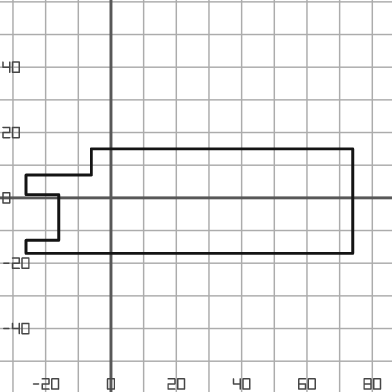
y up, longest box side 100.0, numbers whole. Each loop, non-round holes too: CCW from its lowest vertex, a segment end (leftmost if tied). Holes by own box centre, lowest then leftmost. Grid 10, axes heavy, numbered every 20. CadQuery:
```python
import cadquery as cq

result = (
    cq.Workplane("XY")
    .moveTo(-26.0, -17.0)
    .lineTo(74.0, -17.0)
    .lineTo(74.0, 15.0)
    .lineTo(-6.0, 15.0)
    .lineTo(-6.0, 7.0)
    .lineTo(-26.0, 7.0)
    .lineTo(-26.0, 1.0)
    .lineTo(-16.0, 1.0)
    .lineTo(-16.0, -13.0)
    .lineTo(-26.0, -13.0)
    .close()
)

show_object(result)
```